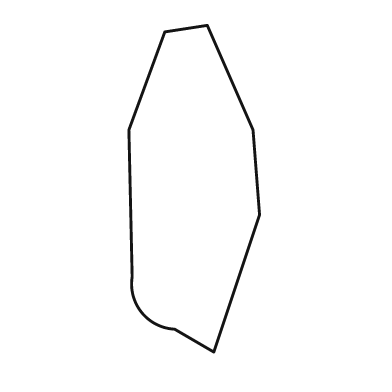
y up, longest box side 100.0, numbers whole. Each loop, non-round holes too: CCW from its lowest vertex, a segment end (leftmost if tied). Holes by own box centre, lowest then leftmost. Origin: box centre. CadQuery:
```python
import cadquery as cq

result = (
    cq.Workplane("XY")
    .moveTo(6.0, -50.0)
    .lineTo(20.0, -8.0)
    .lineTo(18.0, 18.0)
    .lineTo(4.0, 50.0)
    .lineTo(-9.0, 48.0)
    .lineTo(-20.0, 18.0)
    .lineTo(-19.0, -27.0)
    .threePointArc((-16.0, -38.0), (-6.0, -43.0))
    .close()
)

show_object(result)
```